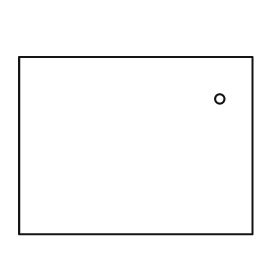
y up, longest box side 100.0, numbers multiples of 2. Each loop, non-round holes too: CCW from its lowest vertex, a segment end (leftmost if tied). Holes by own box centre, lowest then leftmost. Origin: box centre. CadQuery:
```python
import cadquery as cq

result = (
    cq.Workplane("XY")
    .moveTo(-50.0, -38.0)
    .lineTo(50.0, -38.0)
    .lineTo(50.0, 38.0)
    .lineTo(-50.0, 38.0)
    .close()
    .moveTo(36.0, 20.0)
    .circle(2.0)
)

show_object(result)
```